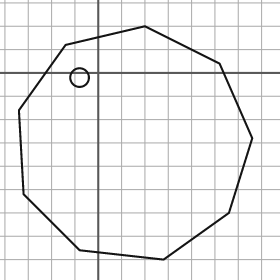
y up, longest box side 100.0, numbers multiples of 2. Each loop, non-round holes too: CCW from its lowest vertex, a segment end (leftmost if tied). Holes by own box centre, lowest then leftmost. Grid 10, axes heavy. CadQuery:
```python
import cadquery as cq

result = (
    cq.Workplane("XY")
    .moveTo(28.0, -80.0)
    .lineTo(56.0, -60.0)
    .lineTo(66.0, -28.0)
    .lineTo(52.0, 4.0)
    .lineTo(20.0, 20.0)
    .lineTo(-14.0, 12.0)
    .lineTo(-34.0, -16.0)
    .lineTo(-32.0, -52.0)
    .lineTo(-8.0, -76.0)
    .close()
    .moveTo(-8.0, -2.0)
    .circle(4.0)
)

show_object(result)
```